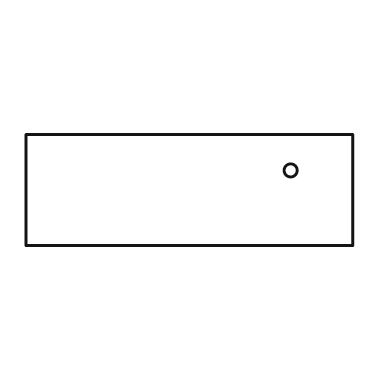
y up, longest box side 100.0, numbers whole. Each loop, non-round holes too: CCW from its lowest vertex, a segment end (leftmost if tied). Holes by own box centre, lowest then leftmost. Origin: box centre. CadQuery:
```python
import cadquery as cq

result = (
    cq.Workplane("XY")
    .moveTo(-50.0, -17.0)
    .lineTo(50.0, -17.0)
    .lineTo(50.0, 17.0)
    .lineTo(-50.0, 17.0)
    .close()
    .moveTo(31.0, 6.0)
    .circle(2.0)
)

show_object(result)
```